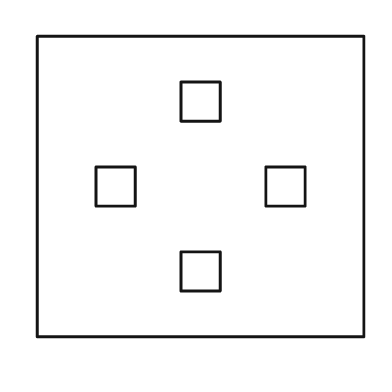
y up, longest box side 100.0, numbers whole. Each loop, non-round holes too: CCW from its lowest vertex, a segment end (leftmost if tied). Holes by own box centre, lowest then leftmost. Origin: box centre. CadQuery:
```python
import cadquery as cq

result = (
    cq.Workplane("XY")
    .moveTo(-50.0, -46.0)
    .lineTo(50.0, -46.0)
    .lineTo(50.0, 46.0)
    .lineTo(-50.0, 46.0)
    .close()
    .moveTo(-6.0, -32.0)
    .lineTo(6.0, -32.0)
    .lineTo(6.0, -20.0)
    .lineTo(-6.0, -20.0)
    .close()
    .moveTo(-32.0, -6.0)
    .lineTo(-20.0, -6.0)
    .lineTo(-20.0, 6.0)
    .lineTo(-32.0, 6.0)
    .close()
    .moveTo(20.0, -6.0)
    .lineTo(32.0, -6.0)
    .lineTo(32.0, 6.0)
    .lineTo(20.0, 6.0)
    .close()
    .moveTo(-6.0, 20.0)
    .lineTo(6.0, 20.0)
    .lineTo(6.0, 32.0)
    .lineTo(-6.0, 32.0)
    .close()
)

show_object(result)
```